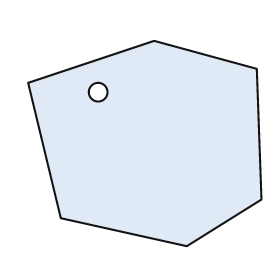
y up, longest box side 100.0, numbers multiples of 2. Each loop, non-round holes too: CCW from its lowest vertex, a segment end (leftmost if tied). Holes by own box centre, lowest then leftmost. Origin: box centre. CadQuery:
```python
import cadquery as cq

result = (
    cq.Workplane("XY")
    .moveTo(18.0, -44.0)
    .lineTo(50.0, -24.0)
    .lineTo(48.0, 32.0)
    .lineTo(4.0, 44.0)
    .lineTo(-50.0, 26.0)
    .lineTo(-36.0, -32.0)
    .close()
    .moveTo(-20.0, 22.0)
    .circle(4.0)
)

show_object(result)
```